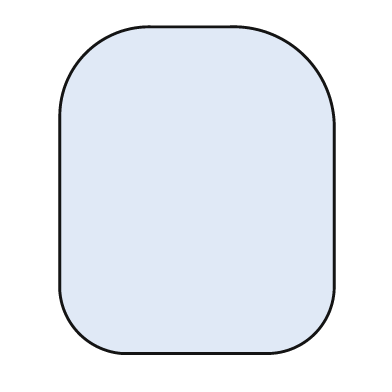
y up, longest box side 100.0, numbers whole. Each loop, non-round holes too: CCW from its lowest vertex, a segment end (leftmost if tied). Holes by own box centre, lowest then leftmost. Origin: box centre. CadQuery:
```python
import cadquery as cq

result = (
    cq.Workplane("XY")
    .moveTo(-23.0, -50.0)
    .lineTo(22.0, -50.0)
    .threePointArc((36.0, -44.0), (42.0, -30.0))
    .lineTo(42.0, 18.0)
    .threePointArc((33.0, 41.0), (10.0, 50.0))
    .lineTo(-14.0, 50.0)
    .threePointArc((-34.0, 42.0), (-42.0, 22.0))
    .lineTo(-42.0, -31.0)
    .threePointArc((-36.0, -44.0), (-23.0, -50.0))
    .close()
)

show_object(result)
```